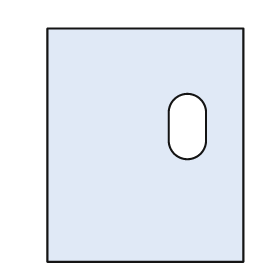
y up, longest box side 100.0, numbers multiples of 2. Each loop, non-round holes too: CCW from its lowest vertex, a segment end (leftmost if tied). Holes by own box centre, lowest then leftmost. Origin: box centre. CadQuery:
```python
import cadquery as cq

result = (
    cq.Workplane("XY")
    .moveTo(-42.0, -50.0)
    .lineTo(42.0, -50.0)
    .lineTo(42.0, 50.0)
    .lineTo(-42.0, 50.0)
    .close()
    .moveTo(10.0, 2.0)
    .threePointArc((18.0, -6.0), (26.0, 2.0))
    .lineTo(26.0, 14.0)
    .threePointArc((18.0, 22.0), (10.0, 14.0))
    .close()
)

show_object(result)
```